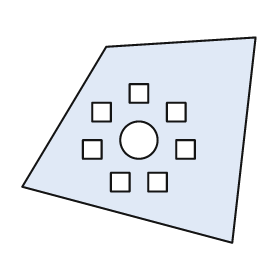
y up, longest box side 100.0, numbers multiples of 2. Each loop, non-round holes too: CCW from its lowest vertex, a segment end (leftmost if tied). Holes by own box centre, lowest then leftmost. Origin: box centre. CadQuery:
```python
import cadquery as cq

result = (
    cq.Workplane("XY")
    .moveTo(40.0, -44.0)
    .lineTo(50.0, 44.0)
    .lineTo(-14.0, 40.0)
    .lineTo(-50.0, -20.0)
    .close()
    .moveTo(-12.0, -22.0)
    .lineTo(-4.0, -22.0)
    .lineTo(-4.0, -14.0)
    .lineTo(-12.0, -14.0)
    .close()
    .moveTo(4.0, -22.0)
    .lineTo(12.0, -22.0)
    .lineTo(12.0, -14.0)
    .lineTo(4.0, -14.0)
    .close()
    .moveTo(-24.0, -8.0)
    .lineTo(-16.0, -8.0)
    .lineTo(-16.0, 0.0)
    .lineTo(-24.0, 0.0)
    .close()
    .moveTo(16.0, -8.0)
    .lineTo(24.0, -8.0)
    .lineTo(24.0, 0.0)
    .lineTo(16.0, 0.0)
    .close()
    .moveTo(0.0, 0.0)
    .circle(8.0)
    .moveTo(-20.0, 8.0)
    .lineTo(-12.0, 8.0)
    .lineTo(-12.0, 16.0)
    .lineTo(-20.0, 16.0)
    .close()
    .moveTo(12.0, 8.0)
    .lineTo(20.0, 8.0)
    .lineTo(20.0, 16.0)
    .lineTo(12.0, 16.0)
    .close()
    .moveTo(-4.0, 16.0)
    .lineTo(4.0, 16.0)
    .lineTo(4.0, 24.0)
    .lineTo(-4.0, 24.0)
    .close()
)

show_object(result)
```